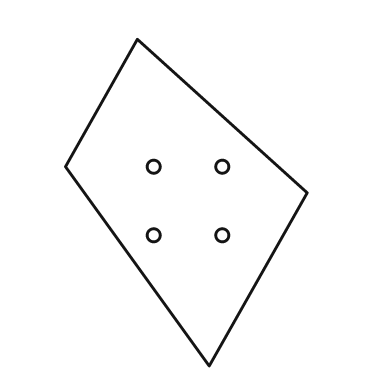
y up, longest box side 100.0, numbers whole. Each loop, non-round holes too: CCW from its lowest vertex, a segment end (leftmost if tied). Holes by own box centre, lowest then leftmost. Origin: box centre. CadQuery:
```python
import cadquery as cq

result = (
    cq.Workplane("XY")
    .moveTo(7.0, -50.0)
    .lineTo(37.0, 3.0)
    .lineTo(-15.0, 50.0)
    .lineTo(-37.0, 11.0)
    .close()
    .moveTo(-10.0, -10.0)
    .circle(2.0)
    .moveTo(11.0, -10.0)
    .circle(2.0)
    .moveTo(-10.0, 11.0)
    .circle(2.0)
    .moveTo(11.0, 11.0)
    .circle(2.0)
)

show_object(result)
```